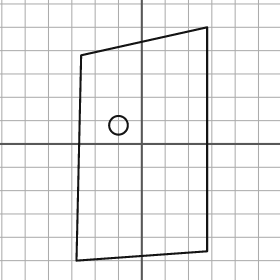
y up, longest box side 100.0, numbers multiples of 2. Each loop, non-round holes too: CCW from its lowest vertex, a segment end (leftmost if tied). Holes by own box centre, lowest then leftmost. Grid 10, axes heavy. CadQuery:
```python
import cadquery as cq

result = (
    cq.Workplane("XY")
    .moveTo(-28.0, -50.0)
    .lineTo(28.0, -46.0)
    .lineTo(28.0, 50.0)
    .lineTo(-26.0, 38.0)
    .close()
    .moveTo(-10.0, 8.0)
    .circle(4.0)
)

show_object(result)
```